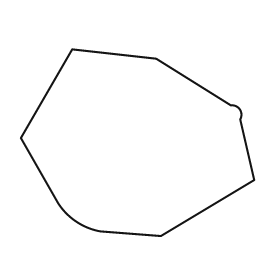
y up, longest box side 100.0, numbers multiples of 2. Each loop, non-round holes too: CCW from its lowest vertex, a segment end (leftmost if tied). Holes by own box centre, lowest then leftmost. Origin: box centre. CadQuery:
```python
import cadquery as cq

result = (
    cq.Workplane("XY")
    .moveTo(10.0, -40.0)
    .lineTo(50.0, -16.0)
    .lineTo(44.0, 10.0)
    .threePointArc((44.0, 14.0), (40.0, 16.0))
    .lineTo(8.0, 36.0)
    .lineTo(-28.0, 40.0)
    .lineTo(-50.0, 2.0)
    .lineTo(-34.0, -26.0)
    .threePointArc((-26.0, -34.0), (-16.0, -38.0))
    .close()
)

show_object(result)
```